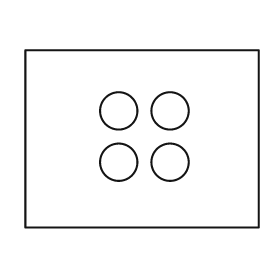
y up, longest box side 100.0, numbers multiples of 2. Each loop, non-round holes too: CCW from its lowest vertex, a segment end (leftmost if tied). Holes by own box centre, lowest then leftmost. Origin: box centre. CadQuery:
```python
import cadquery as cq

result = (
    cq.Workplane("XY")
    .moveTo(-50.0, -38.0)
    .lineTo(50.0, -38.0)
    .lineTo(50.0, 38.0)
    .lineTo(-50.0, 38.0)
    .close()
    .moveTo(-10.0, -10.0)
    .circle(8.0)
    .moveTo(12.0, -10.0)
    .circle(8.0)
    .moveTo(-10.0, 12.0)
    .circle(8.0)
    .moveTo(12.0, 12.0)
    .circle(8.0)
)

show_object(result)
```